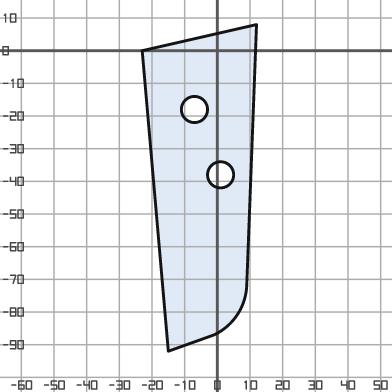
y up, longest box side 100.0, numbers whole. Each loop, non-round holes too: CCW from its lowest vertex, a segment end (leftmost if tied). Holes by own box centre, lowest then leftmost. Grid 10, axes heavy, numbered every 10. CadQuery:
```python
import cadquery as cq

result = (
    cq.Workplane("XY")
    .moveTo(-15.0, -92.0)
    .lineTo(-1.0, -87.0)
    .threePointArc((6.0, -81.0), (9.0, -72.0))
    .lineTo(12.0, 8.0)
    .lineTo(-23.0, 0.0)
    .close()
    .moveTo(1.0, -38.0)
    .circle(4.0)
    .moveTo(-7.0, -18.0)
    .circle(4.0)
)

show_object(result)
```